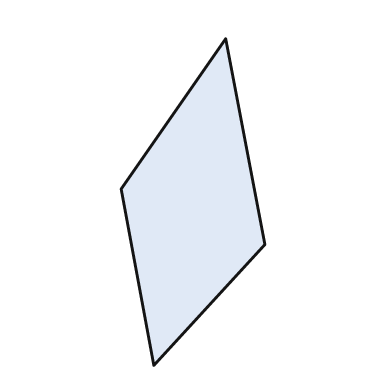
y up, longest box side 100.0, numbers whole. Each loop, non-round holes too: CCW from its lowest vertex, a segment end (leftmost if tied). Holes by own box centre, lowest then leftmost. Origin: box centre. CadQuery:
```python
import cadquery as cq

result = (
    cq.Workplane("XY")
    .moveTo(-12.0, -50.0)
    .lineTo(22.0, -13.0)
    .lineTo(10.0, 50.0)
    .lineTo(-22.0, 4.0)
    .close()
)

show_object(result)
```